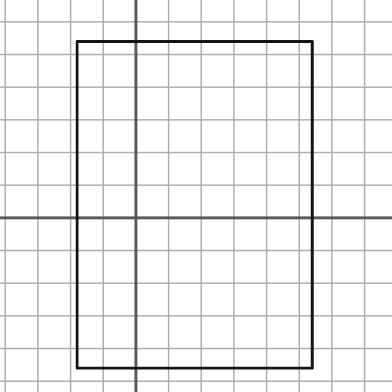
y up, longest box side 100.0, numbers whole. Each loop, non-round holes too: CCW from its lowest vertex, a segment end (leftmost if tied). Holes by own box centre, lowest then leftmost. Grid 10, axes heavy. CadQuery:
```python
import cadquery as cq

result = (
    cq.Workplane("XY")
    .moveTo(-18.0, -46.0)
    .lineTo(54.0, -46.0)
    .lineTo(54.0, 54.0)
    .lineTo(-18.0, 54.0)
    .close()
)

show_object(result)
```